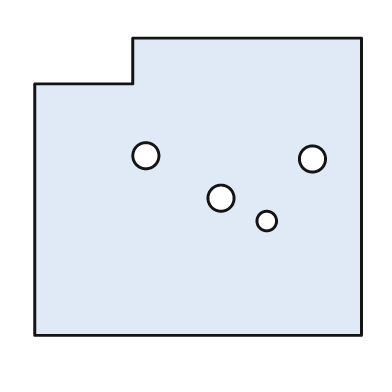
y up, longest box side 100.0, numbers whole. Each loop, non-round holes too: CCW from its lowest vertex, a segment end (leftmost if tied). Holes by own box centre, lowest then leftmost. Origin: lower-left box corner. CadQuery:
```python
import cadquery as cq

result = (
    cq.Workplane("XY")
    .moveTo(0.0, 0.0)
    .lineTo(100.0, 0.0)
    .lineTo(100.0, 91.0)
    .lineTo(30.0, 91.0)
    .lineTo(30.0, 77.0)
    .lineTo(0.0, 77.0)
    .close()
    .moveTo(71.0, 35.0)
    .circle(3.0)
    .moveTo(57.0, 42.0)
    .circle(4.0)
    .moveTo(85.0, 54.0)
    .circle(4.0)
    .moveTo(34.0, 55.0)
    .circle(4.0)
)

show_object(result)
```